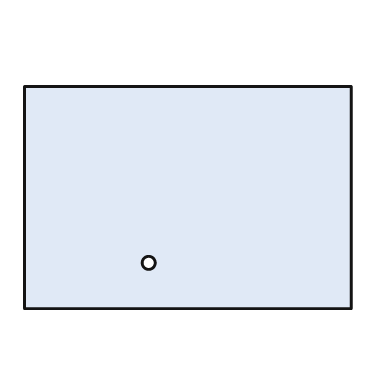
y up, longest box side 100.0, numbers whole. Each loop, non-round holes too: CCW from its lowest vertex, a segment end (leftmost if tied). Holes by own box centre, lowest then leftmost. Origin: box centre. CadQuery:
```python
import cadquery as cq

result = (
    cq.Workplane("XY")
    .moveTo(-50.0, -34.0)
    .lineTo(50.0, -34.0)
    .lineTo(50.0, 34.0)
    .lineTo(-50.0, 34.0)
    .close()
    .moveTo(-12.0, -20.0)
    .circle(2.0)
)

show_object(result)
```